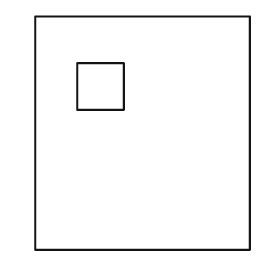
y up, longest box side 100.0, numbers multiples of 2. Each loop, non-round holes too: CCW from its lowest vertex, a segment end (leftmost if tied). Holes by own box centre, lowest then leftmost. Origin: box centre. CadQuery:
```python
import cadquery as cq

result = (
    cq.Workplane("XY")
    .moveTo(-46.0, -50.0)
    .lineTo(46.0, -50.0)
    .lineTo(46.0, 50.0)
    .lineTo(-46.0, 50.0)
    .close()
    .moveTo(-28.0, 10.0)
    .lineTo(-8.0, 10.0)
    .lineTo(-8.0, 30.0)
    .lineTo(-28.0, 30.0)
    .close()
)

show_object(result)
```